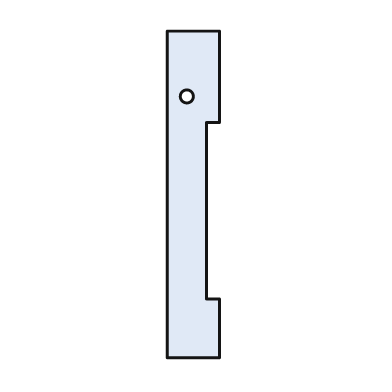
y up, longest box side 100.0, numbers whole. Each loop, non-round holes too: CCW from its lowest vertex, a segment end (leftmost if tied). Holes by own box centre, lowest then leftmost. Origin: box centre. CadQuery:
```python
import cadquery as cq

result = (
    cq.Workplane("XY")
    .moveTo(-8.0, -50.0)
    .lineTo(8.0, -50.0)
    .lineTo(8.0, -32.0)
    .lineTo(4.0, -32.0)
    .lineTo(4.0, 22.0)
    .lineTo(8.0, 22.0)
    .lineTo(8.0, 50.0)
    .lineTo(-8.0, 50.0)
    .close()
    .moveTo(-2.0, 30.0)
    .circle(2.0)
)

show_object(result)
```